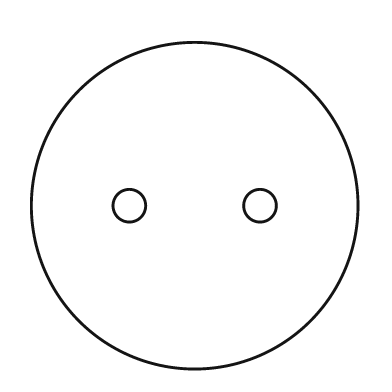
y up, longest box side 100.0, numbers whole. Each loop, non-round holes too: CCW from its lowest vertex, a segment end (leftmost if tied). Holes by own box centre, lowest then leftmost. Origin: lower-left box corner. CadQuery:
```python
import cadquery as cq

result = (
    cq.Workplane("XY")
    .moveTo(50.0, 50.0)
    .circle(50.0)
    .moveTo(30.0, 50.0)
    .circle(5.0)
    .moveTo(70.0, 50.0)
    .circle(5.0)
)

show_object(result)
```